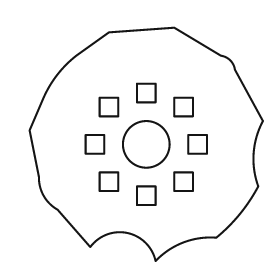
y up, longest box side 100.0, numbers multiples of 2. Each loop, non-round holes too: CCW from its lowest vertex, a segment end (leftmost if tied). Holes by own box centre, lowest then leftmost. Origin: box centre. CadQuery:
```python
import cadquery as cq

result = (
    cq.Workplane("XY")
    .moveTo(4.0, -50.0)
    .threePointArc((16.0, -42.0), (30.0, -40.0))
    .threePointArc((40.0, -30.0), (48.0, -18.0))
    .threePointArc((46.0, -4.0), (50.0, 10.0))
    .lineTo(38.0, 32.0)
    .threePointArc((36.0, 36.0), (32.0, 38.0))
    .lineTo(12.0, 50.0)
    .lineTo(-16.0, 48.0)
    .lineTo(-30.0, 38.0)
    .threePointArc((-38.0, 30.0), (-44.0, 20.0))
    .lineTo(-50.0, 6.0)
    .lineTo(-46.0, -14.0)
    .threePointArc((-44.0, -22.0), (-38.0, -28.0))
    .lineTo(-24.0, -44.0)
    .threePointArc((-8.0, -38.0), (4.0, -50.0))
    .close()
    .moveTo(-4.0, -26.0)
    .lineTo(4.0, -26.0)
    .lineTo(4.0, -18.0)
    .lineTo(-4.0, -18.0)
    .close()
    .moveTo(-20.0, -20.0)
    .lineTo(-12.0, -20.0)
    .lineTo(-12.0, -12.0)
    .lineTo(-20.0, -12.0)
    .close()
    .moveTo(12.0, -20.0)
    .lineTo(20.0, -20.0)
    .lineTo(20.0, -12.0)
    .lineTo(12.0, -12.0)
    .close()
    .moveTo(-26.0, -4.0)
    .lineTo(-18.0, -4.0)
    .lineTo(-18.0, 4.0)
    .lineTo(-26.0, 4.0)
    .close()
    .moveTo(0.0, 0.0)
    .circle(10.0)
    .moveTo(18.0, -4.0)
    .lineTo(26.0, -4.0)
    .lineTo(26.0, 4.0)
    .lineTo(18.0, 4.0)
    .close()
    .moveTo(-20.0, 12.0)
    .lineTo(-12.0, 12.0)
    .lineTo(-12.0, 20.0)
    .lineTo(-20.0, 20.0)
    .close()
    .moveTo(12.0, 12.0)
    .lineTo(20.0, 12.0)
    .lineTo(20.0, 20.0)
    .lineTo(12.0, 20.0)
    .close()
    .moveTo(-4.0, 18.0)
    .lineTo(4.0, 18.0)
    .lineTo(4.0, 26.0)
    .lineTo(-4.0, 26.0)
    .close()
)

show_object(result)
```